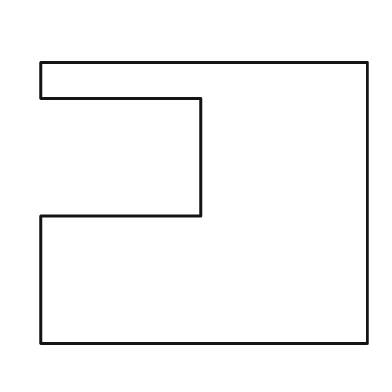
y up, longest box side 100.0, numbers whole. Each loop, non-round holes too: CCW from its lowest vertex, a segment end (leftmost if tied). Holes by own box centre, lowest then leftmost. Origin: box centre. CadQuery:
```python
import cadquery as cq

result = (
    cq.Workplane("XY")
    .moveTo(-50.0, -43.0)
    .lineTo(50.0, -43.0)
    .lineTo(50.0, 43.0)
    .lineTo(-50.0, 43.0)
    .lineTo(-50.0, 32.0)
    .lineTo(-1.0, 32.0)
    .lineTo(-1.0, -4.0)
    .lineTo(-50.0, -4.0)
    .close()
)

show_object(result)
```